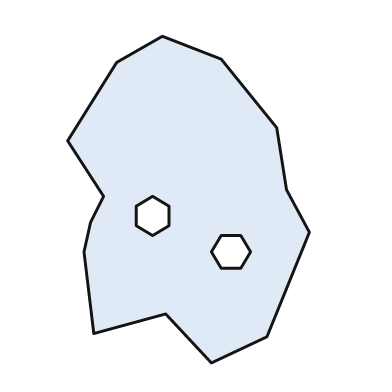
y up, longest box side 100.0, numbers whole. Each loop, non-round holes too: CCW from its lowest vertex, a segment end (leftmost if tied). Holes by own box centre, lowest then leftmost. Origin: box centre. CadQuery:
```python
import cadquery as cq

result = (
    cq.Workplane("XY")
    .moveTo(7.0, -50.0)
    .lineTo(24.0, -42.0)
    .lineTo(37.0, -10.0)
    .lineTo(30.0, 3.0)
    .lineTo(27.0, 22.0)
    .lineTo(10.0, 43.0)
    .lineTo(-8.0, 50.0)
    .lineTo(-22.0, 42.0)
    .lineTo(-37.0, 18.0)
    .lineTo(-26.0, 1.0)
    .lineTo(-30.0, -7.0)
    .lineTo(-32.0, -16.0)
    .lineTo(-29.0, -41.0)
    .lineTo(-7.0, -35.0)
    .close()
    .moveTo(10.0, -21.0)
    .lineTo(16.0, -21.0)
    .lineTo(19.0, -16.0)
    .lineTo(16.0, -11.0)
    .lineTo(10.0, -11.0)
    .lineTo(7.0, -16.0)
    .close()
    .moveTo(-11.0, -11.0)
    .lineTo(-6.0, -8.0)
    .lineTo(-6.0, -2.0)
    .lineTo(-11.0, 1.0)
    .lineTo(-16.0, -2.0)
    .lineTo(-16.0, -8.0)
    .close()
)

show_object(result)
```